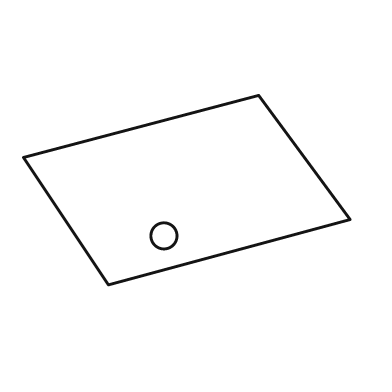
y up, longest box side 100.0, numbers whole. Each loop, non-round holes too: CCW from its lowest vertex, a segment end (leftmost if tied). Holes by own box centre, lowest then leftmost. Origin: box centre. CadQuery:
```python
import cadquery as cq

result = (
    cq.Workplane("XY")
    .moveTo(-24.0, -29.0)
    .lineTo(50.0, -9.0)
    .lineTo(22.0, 29.0)
    .lineTo(-50.0, 10.0)
    .close()
    .moveTo(-7.0, -14.0)
    .circle(4.0)
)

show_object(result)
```